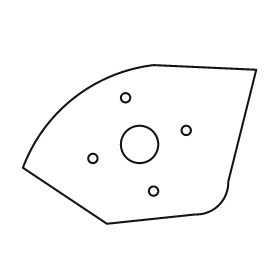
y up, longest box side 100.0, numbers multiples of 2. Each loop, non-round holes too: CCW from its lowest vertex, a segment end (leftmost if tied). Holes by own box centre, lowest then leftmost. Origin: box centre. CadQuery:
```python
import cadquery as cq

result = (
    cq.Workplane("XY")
    .moveTo(-14.0, -34.0)
    .lineTo(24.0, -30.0)
    .threePointArc((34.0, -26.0), (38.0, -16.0))
    .lineTo(50.0, 32.0)
    .lineTo(6.0, 34.0)
    .threePointArc((-28.0, 20.0), (-50.0, -10.0))
    .close()
    .moveTo(6.0, -20.0)
    .circle(2.0)
    .moveTo(-20.0, -6.0)
    .circle(2.0)
    .moveTo(0.0, 0.0)
    .circle(8.0)
    .moveTo(20.0, 6.0)
    .circle(2.0)
    .moveTo(-6.0, 20.0)
    .circle(2.0)
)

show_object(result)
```